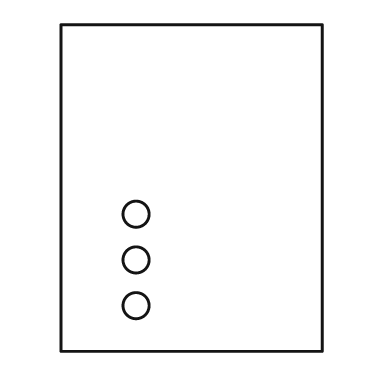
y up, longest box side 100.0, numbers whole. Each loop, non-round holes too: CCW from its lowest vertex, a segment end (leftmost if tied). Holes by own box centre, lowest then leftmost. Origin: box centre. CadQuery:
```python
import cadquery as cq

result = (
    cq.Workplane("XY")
    .moveTo(-40.0, -50.0)
    .lineTo(40.0, -50.0)
    .lineTo(40.0, 50.0)
    .lineTo(-40.0, 50.0)
    .close()
    .moveTo(-17.0, -36.0)
    .circle(4.0)
    .moveTo(-17.0, -22.0)
    .circle(4.0)
    .moveTo(-17.0, -8.0)
    .circle(4.0)
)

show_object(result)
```